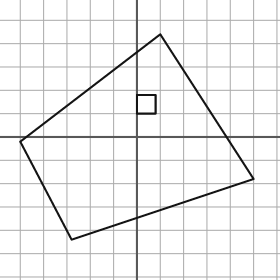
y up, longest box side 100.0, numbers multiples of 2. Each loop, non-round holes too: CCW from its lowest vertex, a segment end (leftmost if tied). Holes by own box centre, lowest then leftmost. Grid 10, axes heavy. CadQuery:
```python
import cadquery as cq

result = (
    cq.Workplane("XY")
    .moveTo(-28.0, -44.0)
    .lineTo(50.0, -18.0)
    .lineTo(10.0, 44.0)
    .lineTo(-50.0, -2.0)
    .close()
    .moveTo(0.0, 10.0)
    .lineTo(8.0, 10.0)
    .lineTo(8.0, 18.0)
    .lineTo(0.0, 18.0)
    .close()
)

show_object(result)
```